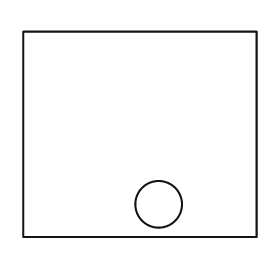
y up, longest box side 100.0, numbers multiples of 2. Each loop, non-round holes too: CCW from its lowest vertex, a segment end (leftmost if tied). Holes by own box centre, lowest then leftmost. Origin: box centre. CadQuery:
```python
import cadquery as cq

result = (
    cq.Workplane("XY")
    .moveTo(-50.0, -44.0)
    .lineTo(50.0, -44.0)
    .lineTo(50.0, 44.0)
    .lineTo(-50.0, 44.0)
    .close()
    .moveTo(8.0, -30.0)
    .circle(10.0)
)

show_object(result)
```